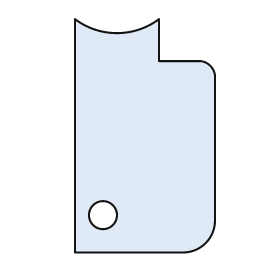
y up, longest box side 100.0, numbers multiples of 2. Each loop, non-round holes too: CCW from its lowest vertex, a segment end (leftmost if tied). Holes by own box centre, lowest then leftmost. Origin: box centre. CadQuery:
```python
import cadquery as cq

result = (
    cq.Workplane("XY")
    .moveTo(-30.0, -50.0)
    .lineTo(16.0, -50.0)
    .threePointArc((26.0, -46.0), (30.0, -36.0))
    .lineTo(30.0, 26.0)
    .threePointArc((28.0, 30.0), (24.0, 32.0))
    .lineTo(6.0, 32.0)
    .lineTo(6.0, 50.0)
    .threePointArc((-12.0, 44.0), (-30.0, 50.0))
    .close()
    .moveTo(-18.0, -34.0)
    .circle(6.0)
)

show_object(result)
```